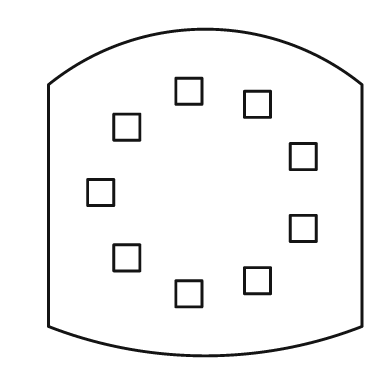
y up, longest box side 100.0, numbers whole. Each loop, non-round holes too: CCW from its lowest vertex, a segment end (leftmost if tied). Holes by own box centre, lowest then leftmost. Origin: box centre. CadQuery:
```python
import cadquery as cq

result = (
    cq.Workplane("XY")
    .moveTo(-48.0, -41.0)
    .threePointArc((0.0, -50.0), (48.0, -41.0))
    .lineTo(48.0, 33.0)
    .threePointArc((0.0, 50.0), (-48.0, 33.0))
    .close()
    .moveTo(-9.0, -35.0)
    .lineTo(-1.0, -35.0)
    .lineTo(-1.0, -27.0)
    .lineTo(-9.0, -27.0)
    .close()
    .moveTo(12.0, -31.0)
    .lineTo(20.0, -31.0)
    .lineTo(20.0, -23.0)
    .lineTo(12.0, -23.0)
    .close()
    .moveTo(-28.0, -24.0)
    .lineTo(-20.0, -24.0)
    .lineTo(-20.0, -16.0)
    .lineTo(-28.0, -16.0)
    .close()
    .moveTo(26.0, -15.0)
    .lineTo(34.0, -15.0)
    .lineTo(34.0, -7.0)
    .lineTo(26.0, -7.0)
    .close()
    .moveTo(-36.0, -4.0)
    .lineTo(-28.0, -4.0)
    .lineTo(-28.0, 4.0)
    .lineTo(-36.0, 4.0)
    .close()
    .moveTo(26.0, 7.0)
    .lineTo(34.0, 7.0)
    .lineTo(34.0, 15.0)
    .lineTo(26.0, 15.0)
    .close()
    .moveTo(-28.0, 16.0)
    .lineTo(-20.0, 16.0)
    .lineTo(-20.0, 24.0)
    .lineTo(-28.0, 24.0)
    .close()
    .moveTo(12.0, 23.0)
    .lineTo(20.0, 23.0)
    .lineTo(20.0, 31.0)
    .lineTo(12.0, 31.0)
    .close()
    .moveTo(-9.0, 27.0)
    .lineTo(-1.0, 27.0)
    .lineTo(-1.0, 35.0)
    .lineTo(-9.0, 35.0)
    .close()
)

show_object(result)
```